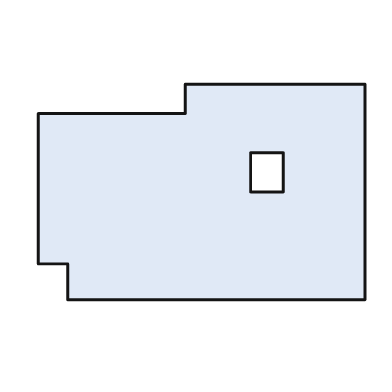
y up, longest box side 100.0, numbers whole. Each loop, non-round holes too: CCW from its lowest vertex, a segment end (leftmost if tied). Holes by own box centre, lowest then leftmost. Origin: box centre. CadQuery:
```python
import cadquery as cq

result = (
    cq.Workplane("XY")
    .moveTo(-41.0, -33.0)
    .lineTo(50.0, -33.0)
    .lineTo(50.0, 33.0)
    .lineTo(-5.0, 33.0)
    .lineTo(-5.0, 24.0)
    .lineTo(-50.0, 24.0)
    .lineTo(-50.0, -22.0)
    .lineTo(-41.0, -22.0)
    .close()
    .moveTo(15.0, 0.0)
    .lineTo(25.0, 0.0)
    .lineTo(25.0, 12.0)
    .lineTo(15.0, 12.0)
    .close()
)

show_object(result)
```